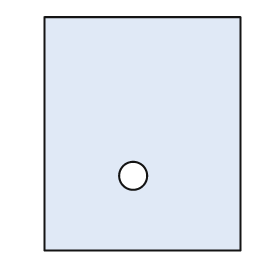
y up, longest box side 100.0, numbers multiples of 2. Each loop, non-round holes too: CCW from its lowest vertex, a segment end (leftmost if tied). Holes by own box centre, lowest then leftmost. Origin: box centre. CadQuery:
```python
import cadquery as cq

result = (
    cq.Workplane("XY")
    .moveTo(-42.0, -50.0)
    .lineTo(42.0, -50.0)
    .lineTo(42.0, 50.0)
    .lineTo(-42.0, 50.0)
    .close()
    .moveTo(-4.0, -18.0)
    .circle(6.0)
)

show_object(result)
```